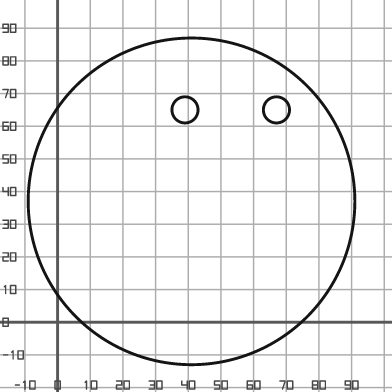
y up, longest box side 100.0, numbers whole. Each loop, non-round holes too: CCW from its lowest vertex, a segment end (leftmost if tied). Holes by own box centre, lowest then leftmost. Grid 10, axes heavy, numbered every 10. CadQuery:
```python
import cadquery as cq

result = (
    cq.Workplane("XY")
    .moveTo(41.0, 37.0)
    .circle(50.0)
    .moveTo(39.0, 65.0)
    .circle(4.0)
    .moveTo(67.0, 65.0)
    .circle(4.0)
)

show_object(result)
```